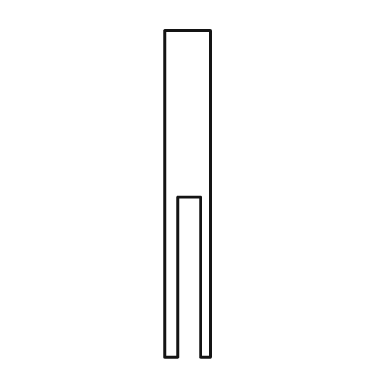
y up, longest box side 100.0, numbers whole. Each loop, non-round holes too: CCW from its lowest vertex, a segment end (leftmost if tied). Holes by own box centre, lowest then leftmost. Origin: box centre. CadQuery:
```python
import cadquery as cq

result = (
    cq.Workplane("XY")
    .moveTo(-7.0, -50.0)
    .lineTo(-3.0, -50.0)
    .lineTo(-3.0, -1.0)
    .lineTo(4.0, -1.0)
    .lineTo(4.0, -50.0)
    .lineTo(7.0, -50.0)
    .lineTo(7.0, 50.0)
    .lineTo(-7.0, 50.0)
    .close()
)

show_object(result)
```